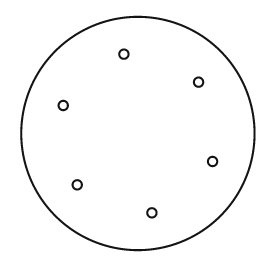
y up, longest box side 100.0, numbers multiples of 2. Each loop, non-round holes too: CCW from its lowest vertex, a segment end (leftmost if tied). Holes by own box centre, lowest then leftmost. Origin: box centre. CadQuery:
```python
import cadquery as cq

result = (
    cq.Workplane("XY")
    .moveTo(0.0, 0.0)
    .circle(50.0)
    .moveTo(6.0, -34.0)
    .circle(2.0)
    .moveTo(-26.0, -22.0)
    .circle(2.0)
    .moveTo(32.0, -12.0)
    .circle(2.0)
    .moveTo(-32.0, 12.0)
    .circle(2.0)
    .moveTo(26.0, 22.0)
    .circle(2.0)
    .moveTo(-6.0, 34.0)
    .circle(2.0)
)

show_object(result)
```